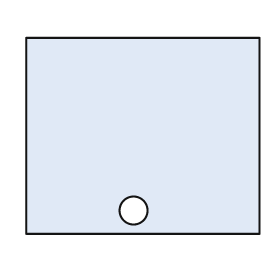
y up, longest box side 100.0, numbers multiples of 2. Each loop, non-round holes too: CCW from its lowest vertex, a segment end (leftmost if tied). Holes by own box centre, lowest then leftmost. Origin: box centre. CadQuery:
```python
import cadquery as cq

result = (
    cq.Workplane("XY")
    .moveTo(-50.0, -42.0)
    .lineTo(50.0, -42.0)
    .lineTo(50.0, 42.0)
    .lineTo(-50.0, 42.0)
    .close()
    .moveTo(-4.0, -32.0)
    .circle(6.0)
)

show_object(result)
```